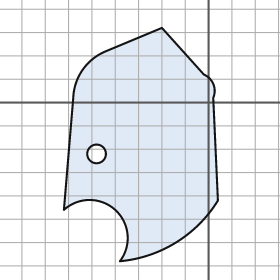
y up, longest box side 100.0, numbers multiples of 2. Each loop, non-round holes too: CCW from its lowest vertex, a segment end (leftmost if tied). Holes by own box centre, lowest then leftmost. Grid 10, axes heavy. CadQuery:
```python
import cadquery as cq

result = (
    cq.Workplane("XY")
    .moveTo(-38.0, -68.0)
    .threePointArc((-14.0, -60.0), (4.0, -42.0))
    .lineTo(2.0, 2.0)
    .threePointArc((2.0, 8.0), (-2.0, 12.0))
    .lineTo(-20.0, 32.0)
    .lineTo(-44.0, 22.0)
    .threePointArc((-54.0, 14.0), (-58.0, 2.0))
    .lineTo(-62.0, -46.0)
    .threePointArc((-40.0, -46.0), (-38.0, -68.0))
    .close()
    .moveTo(-48.0, -22.0)
    .circle(4.0)
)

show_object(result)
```